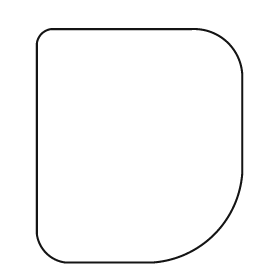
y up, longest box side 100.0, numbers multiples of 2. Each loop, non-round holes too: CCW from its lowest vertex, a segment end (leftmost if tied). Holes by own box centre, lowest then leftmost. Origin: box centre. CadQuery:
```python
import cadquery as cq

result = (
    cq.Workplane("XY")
    .moveTo(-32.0, -50.0)
    .lineTo(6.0, -50.0)
    .threePointArc((32.0, -38.0), (44.0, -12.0))
    .lineTo(44.0, 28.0)
    .threePointArc((38.0, 44.0), (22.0, 50.0))
    .lineTo(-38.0, 50.0)
    .threePointArc((-42.0, 48.0), (-44.0, 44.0))
    .lineTo(-44.0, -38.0)
    .threePointArc((-40.0, -46.0), (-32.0, -50.0))
    .close()
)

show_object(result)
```